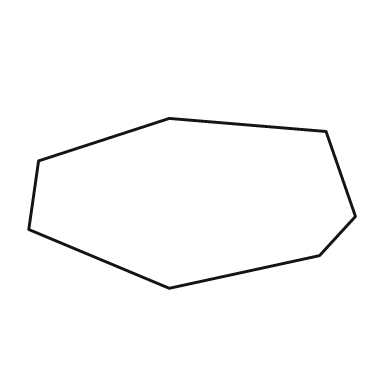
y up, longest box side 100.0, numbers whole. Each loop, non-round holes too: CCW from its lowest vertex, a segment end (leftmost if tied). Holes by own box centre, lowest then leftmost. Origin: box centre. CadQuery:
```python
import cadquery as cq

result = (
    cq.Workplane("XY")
    .moveTo(-7.0, -26.0)
    .lineTo(39.0, -16.0)
    .lineTo(50.0, -4.0)
    .lineTo(41.0, 22.0)
    .lineTo(-7.0, 26.0)
    .lineTo(-47.0, 13.0)
    .lineTo(-50.0, -8.0)
    .close()
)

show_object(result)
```